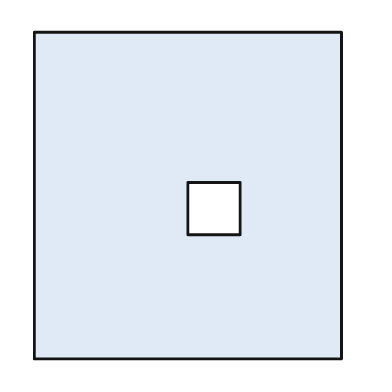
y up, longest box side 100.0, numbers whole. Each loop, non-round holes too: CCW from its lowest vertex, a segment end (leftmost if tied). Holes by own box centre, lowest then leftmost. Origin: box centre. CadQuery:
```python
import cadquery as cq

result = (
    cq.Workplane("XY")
    .moveTo(-47.0, -50.0)
    .lineTo(47.0, -50.0)
    .lineTo(47.0, 50.0)
    .lineTo(-47.0, 50.0)
    .close()
    .moveTo(0.0, -12.0)
    .lineTo(16.0, -12.0)
    .lineTo(16.0, 4.0)
    .lineTo(0.0, 4.0)
    .close()
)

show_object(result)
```